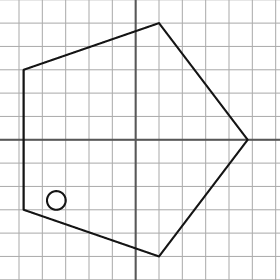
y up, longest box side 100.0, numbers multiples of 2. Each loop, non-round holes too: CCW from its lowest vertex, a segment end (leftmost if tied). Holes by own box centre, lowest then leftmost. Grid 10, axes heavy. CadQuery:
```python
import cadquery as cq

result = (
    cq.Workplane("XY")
    .moveTo(10.0, -50.0)
    .lineTo(48.0, 0.0)
    .lineTo(10.0, 50.0)
    .lineTo(-48.0, 30.0)
    .lineTo(-48.0, -30.0)
    .close()
    .moveTo(-34.0, -26.0)
    .circle(4.0)
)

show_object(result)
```